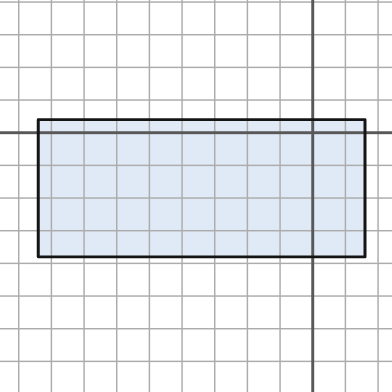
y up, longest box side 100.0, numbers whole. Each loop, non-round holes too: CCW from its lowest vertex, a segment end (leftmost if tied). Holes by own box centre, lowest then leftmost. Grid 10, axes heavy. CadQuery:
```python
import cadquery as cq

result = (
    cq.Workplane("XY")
    .moveTo(-84.0, -38.0)
    .lineTo(16.0, -38.0)
    .lineTo(16.0, 4.0)
    .lineTo(-84.0, 4.0)
    .close()
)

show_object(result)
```